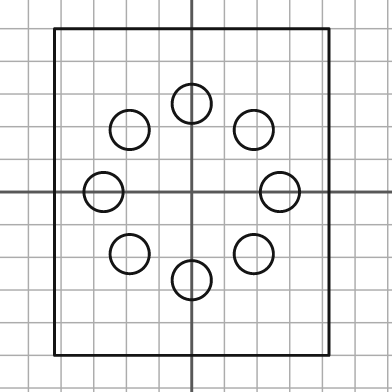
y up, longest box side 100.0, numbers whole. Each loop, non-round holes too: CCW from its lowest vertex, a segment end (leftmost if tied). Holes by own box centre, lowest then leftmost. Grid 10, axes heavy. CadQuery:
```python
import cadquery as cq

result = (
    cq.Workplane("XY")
    .moveTo(-42.0, -50.0)
    .lineTo(42.0, -50.0)
    .lineTo(42.0, 50.0)
    .lineTo(-42.0, 50.0)
    .close()
    .moveTo(0.0, -27.0)
    .circle(6.0)
    .moveTo(-19.0, -19.0)
    .circle(6.0)
    .moveTo(19.0, -19.0)
    .circle(6.0)
    .moveTo(-27.0, 0.0)
    .circle(6.0)
    .moveTo(27.0, 0.0)
    .circle(6.0)
    .moveTo(-19.0, 19.0)
    .circle(6.0)
    .moveTo(19.0, 19.0)
    .circle(6.0)
    .moveTo(0.0, 27.0)
    .circle(6.0)
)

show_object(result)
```